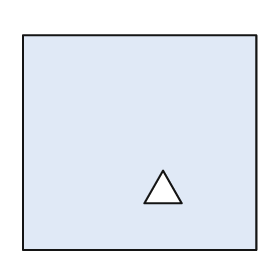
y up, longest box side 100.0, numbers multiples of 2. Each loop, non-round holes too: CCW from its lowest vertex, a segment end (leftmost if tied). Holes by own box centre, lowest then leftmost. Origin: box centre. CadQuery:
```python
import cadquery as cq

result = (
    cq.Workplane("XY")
    .moveTo(-50.0, -46.0)
    .lineTo(50.0, -46.0)
    .lineTo(50.0, 46.0)
    .lineTo(-50.0, 46.0)
    .close()
    .moveTo(2.0, -26.0)
    .lineTo(18.0, -26.0)
    .lineTo(10.0, -12.0)
    .close()
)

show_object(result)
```